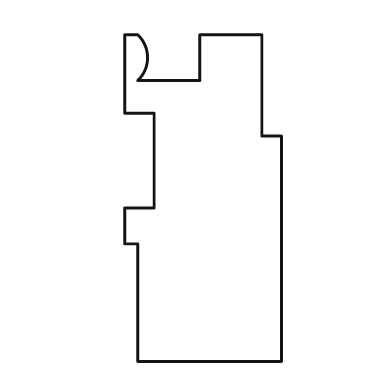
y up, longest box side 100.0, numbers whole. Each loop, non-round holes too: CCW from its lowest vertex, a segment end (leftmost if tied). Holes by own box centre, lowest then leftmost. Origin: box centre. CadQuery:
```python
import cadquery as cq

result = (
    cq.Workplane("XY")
    .moveTo(-20.0, -50.0)
    .lineTo(24.0, -50.0)
    .lineTo(24.0, 19.0)
    .lineTo(18.0, 19.0)
    .lineTo(18.0, 50.0)
    .lineTo(-1.0, 50.0)
    .lineTo(-1.0, 36.0)
    .lineTo(-20.0, 36.0)
    .threePointArc((-17.0, 43.0), (-20.0, 50.0))
    .lineTo(-24.0, 50.0)
    .lineTo(-24.0, 26.0)
    .lineTo(-15.0, 26.0)
    .lineTo(-15.0, -3.0)
    .lineTo(-24.0, -3.0)
    .lineTo(-24.0, -14.0)
    .lineTo(-20.0, -14.0)
    .close()
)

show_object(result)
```